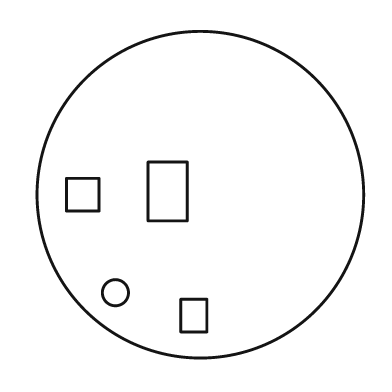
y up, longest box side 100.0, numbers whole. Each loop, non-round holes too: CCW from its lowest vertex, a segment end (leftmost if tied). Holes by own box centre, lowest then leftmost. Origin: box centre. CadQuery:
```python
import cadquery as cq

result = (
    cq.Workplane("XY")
    .moveTo(0.0, 0.0)
    .circle(50.0)
    .moveTo(-6.0, -42.0)
    .lineTo(2.0, -42.0)
    .lineTo(2.0, -32.0)
    .lineTo(-6.0, -32.0)
    .close()
    .moveTo(-26.0, -30.0)
    .circle(4.0)
    .moveTo(-41.0, -5.0)
    .lineTo(-31.0, -5.0)
    .lineTo(-31.0, 5.0)
    .lineTo(-41.0, 5.0)
    .close()
    .moveTo(-16.0, -8.0)
    .lineTo(-4.0, -8.0)
    .lineTo(-4.0, 10.0)
    .lineTo(-16.0, 10.0)
    .close()
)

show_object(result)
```